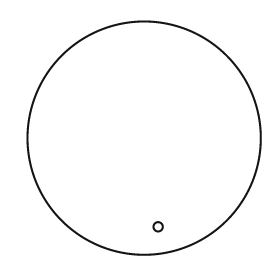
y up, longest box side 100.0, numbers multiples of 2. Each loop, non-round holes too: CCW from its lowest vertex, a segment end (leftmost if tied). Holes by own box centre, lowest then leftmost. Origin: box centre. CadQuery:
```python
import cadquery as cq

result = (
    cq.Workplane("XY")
    .moveTo(0.0, 0.0)
    .circle(50.0)
    .moveTo(6.0, -38.0)
    .circle(2.0)
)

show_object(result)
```